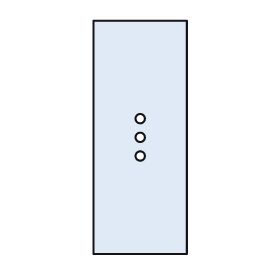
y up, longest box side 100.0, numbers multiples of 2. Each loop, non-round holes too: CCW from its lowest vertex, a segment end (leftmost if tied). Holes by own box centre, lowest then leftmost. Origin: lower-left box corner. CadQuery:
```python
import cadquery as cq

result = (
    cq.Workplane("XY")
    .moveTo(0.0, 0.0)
    .lineTo(40.0, 0.0)
    .lineTo(40.0, 100.0)
    .lineTo(0.0, 100.0)
    .close()
    .moveTo(20.0, 42.0)
    .circle(2.0)
    .moveTo(20.0, 50.0)
    .circle(2.0)
    .moveTo(20.0, 58.0)
    .circle(2.0)
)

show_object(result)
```